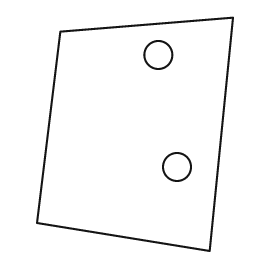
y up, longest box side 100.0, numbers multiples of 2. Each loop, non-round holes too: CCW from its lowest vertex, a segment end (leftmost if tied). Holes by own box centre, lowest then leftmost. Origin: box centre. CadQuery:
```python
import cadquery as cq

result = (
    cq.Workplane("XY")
    .moveTo(32.0, -50.0)
    .lineTo(42.0, 50.0)
    .lineTo(-32.0, 44.0)
    .lineTo(-42.0, -38.0)
    .close()
    .moveTo(18.0, -14.0)
    .circle(6.0)
    .moveTo(10.0, 34.0)
    .circle(6.0)
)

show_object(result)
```